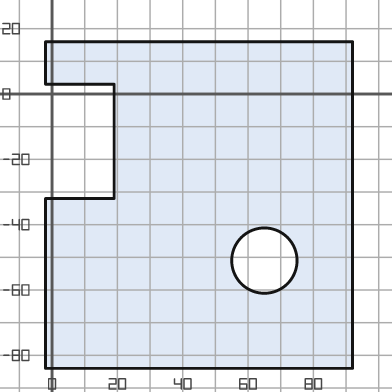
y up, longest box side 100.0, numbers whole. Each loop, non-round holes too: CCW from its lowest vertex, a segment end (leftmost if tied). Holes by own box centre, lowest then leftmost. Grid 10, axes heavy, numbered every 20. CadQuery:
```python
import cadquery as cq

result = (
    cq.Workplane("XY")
    .moveTo(-2.0, -84.0)
    .lineTo(92.0, -84.0)
    .lineTo(92.0, 16.0)
    .lineTo(-2.0, 16.0)
    .lineTo(-2.0, 3.0)
    .lineTo(19.0, 3.0)
    .lineTo(19.0, -32.0)
    .lineTo(-2.0, -32.0)
    .close()
    .moveTo(65.0, -51.0)
    .circle(10.0)
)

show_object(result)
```